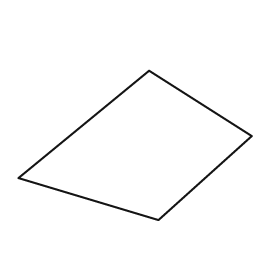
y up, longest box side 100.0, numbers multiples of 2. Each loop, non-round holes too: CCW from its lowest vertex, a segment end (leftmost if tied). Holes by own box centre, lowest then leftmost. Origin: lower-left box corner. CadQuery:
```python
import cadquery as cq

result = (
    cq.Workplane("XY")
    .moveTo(60.0, 0.0)
    .lineTo(100.0, 36.0)
    .lineTo(56.0, 64.0)
    .lineTo(0.0, 18.0)
    .close()
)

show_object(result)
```